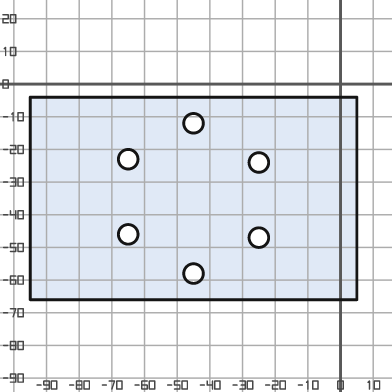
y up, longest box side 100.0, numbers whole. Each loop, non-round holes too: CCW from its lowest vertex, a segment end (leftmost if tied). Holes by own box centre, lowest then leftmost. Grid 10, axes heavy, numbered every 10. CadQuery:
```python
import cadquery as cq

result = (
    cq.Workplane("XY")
    .moveTo(-95.0, -66.0)
    .lineTo(5.0, -66.0)
    .lineTo(5.0, -4.0)
    .lineTo(-95.0, -4.0)
    .close()
    .moveTo(-45.0, -58.0)
    .circle(3.0)
    .moveTo(-25.0, -47.0)
    .circle(3.0)
    .moveTo(-65.0, -46.0)
    .circle(3.0)
    .moveTo(-25.0, -24.0)
    .circle(3.0)
    .moveTo(-65.0, -23.0)
    .circle(3.0)
    .moveTo(-45.0, -12.0)
    .circle(3.0)
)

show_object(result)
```